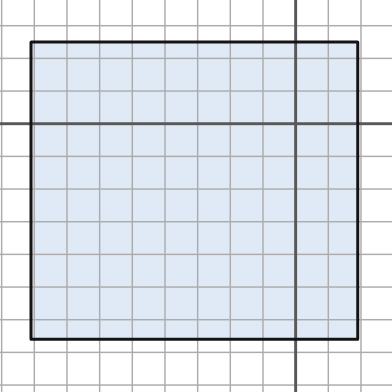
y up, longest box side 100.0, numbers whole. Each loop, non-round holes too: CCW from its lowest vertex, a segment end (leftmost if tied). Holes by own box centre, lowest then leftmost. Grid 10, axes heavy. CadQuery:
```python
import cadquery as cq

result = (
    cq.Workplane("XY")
    .moveTo(-81.0, -66.0)
    .lineTo(19.0, -66.0)
    .lineTo(19.0, 25.0)
    .lineTo(-81.0, 25.0)
    .close()
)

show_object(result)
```